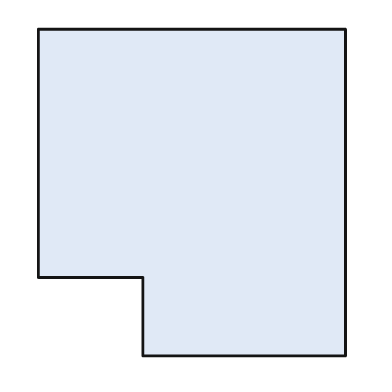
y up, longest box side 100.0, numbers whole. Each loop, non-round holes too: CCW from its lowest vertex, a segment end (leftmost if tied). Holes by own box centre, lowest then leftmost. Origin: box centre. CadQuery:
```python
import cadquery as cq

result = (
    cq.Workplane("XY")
    .moveTo(-15.0, -50.0)
    .lineTo(47.0, -50.0)
    .lineTo(47.0, 50.0)
    .lineTo(-47.0, 50.0)
    .lineTo(-47.0, -26.0)
    .lineTo(-15.0, -26.0)
    .close()
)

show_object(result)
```